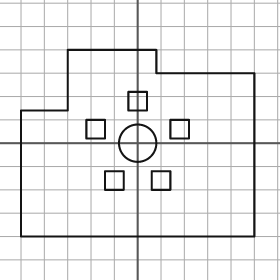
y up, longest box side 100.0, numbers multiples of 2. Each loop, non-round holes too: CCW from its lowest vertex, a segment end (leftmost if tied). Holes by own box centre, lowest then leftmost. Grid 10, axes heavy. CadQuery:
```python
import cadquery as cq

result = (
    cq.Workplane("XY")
    .moveTo(-50.0, -40.0)
    .lineTo(50.0, -40.0)
    .lineTo(50.0, 30.0)
    .lineTo(8.0, 30.0)
    .lineTo(8.0, 40.0)
    .lineTo(-30.0, 40.0)
    .lineTo(-30.0, 14.0)
    .lineTo(-50.0, 14.0)
    .close()
    .moveTo(-14.0, -20.0)
    .lineTo(-6.0, -20.0)
    .lineTo(-6.0, -12.0)
    .lineTo(-14.0, -12.0)
    .close()
    .moveTo(6.0, -20.0)
    .lineTo(14.0, -20.0)
    .lineTo(14.0, -12.0)
    .lineTo(6.0, -12.0)
    .close()
    .moveTo(0.0, 0.0)
    .circle(8.0)
    .moveTo(-22.0, 2.0)
    .lineTo(-14.0, 2.0)
    .lineTo(-14.0, 10.0)
    .lineTo(-22.0, 10.0)
    .close()
    .moveTo(14.0, 2.0)
    .lineTo(22.0, 2.0)
    .lineTo(22.0, 10.0)
    .lineTo(14.0, 10.0)
    .close()
    .moveTo(-4.0, 14.0)
    .lineTo(4.0, 14.0)
    .lineTo(4.0, 22.0)
    .lineTo(-4.0, 22.0)
    .close()
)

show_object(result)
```